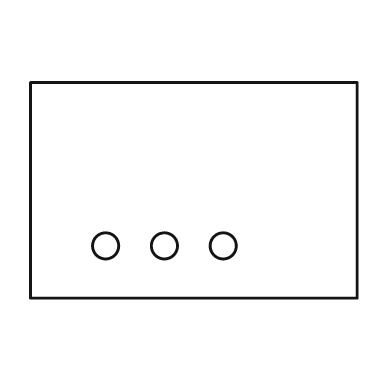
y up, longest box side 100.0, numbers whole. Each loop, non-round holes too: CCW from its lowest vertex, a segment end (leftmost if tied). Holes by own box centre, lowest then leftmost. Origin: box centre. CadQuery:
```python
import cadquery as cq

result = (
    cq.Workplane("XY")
    .moveTo(-50.0, -33.0)
    .lineTo(50.0, -33.0)
    .lineTo(50.0, 33.0)
    .lineTo(-50.0, 33.0)
    .close()
    .moveTo(-27.0, -17.0)
    .circle(4.0)
    .moveTo(-9.0, -17.0)
    .circle(4.0)
    .moveTo(9.0, -17.0)
    .circle(4.0)
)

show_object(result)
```